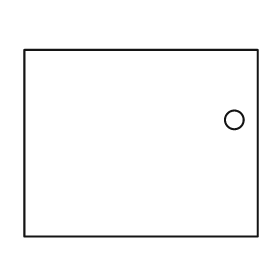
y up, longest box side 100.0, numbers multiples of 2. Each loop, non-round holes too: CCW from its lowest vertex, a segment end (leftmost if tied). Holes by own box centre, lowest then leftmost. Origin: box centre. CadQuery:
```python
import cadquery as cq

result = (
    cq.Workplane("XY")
    .moveTo(-50.0, -40.0)
    .lineTo(50.0, -40.0)
    .lineTo(50.0, 40.0)
    .lineTo(-50.0, 40.0)
    .close()
    .moveTo(40.0, 10.0)
    .circle(4.0)
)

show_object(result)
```